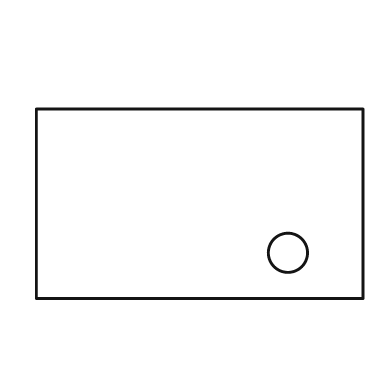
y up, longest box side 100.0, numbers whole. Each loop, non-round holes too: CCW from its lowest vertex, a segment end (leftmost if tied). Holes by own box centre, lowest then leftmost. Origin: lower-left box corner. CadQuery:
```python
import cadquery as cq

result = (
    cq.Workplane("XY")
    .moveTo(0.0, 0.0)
    .lineTo(100.0, 0.0)
    .lineTo(100.0, 58.0)
    .lineTo(0.0, 58.0)
    .close()
    .moveTo(77.0, 14.0)
    .circle(6.0)
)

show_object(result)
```